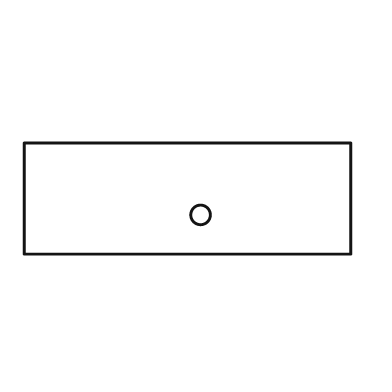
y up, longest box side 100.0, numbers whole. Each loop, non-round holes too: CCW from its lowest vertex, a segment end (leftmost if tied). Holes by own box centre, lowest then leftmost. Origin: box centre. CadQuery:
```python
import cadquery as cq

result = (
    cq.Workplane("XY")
    .moveTo(-50.0, -17.0)
    .lineTo(50.0, -17.0)
    .lineTo(50.0, 17.0)
    .lineTo(-50.0, 17.0)
    .close()
    .moveTo(4.0, -5.0)
    .circle(3.0)
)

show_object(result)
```